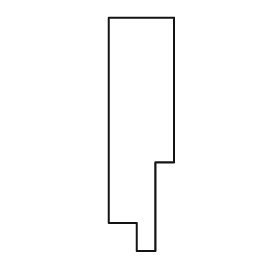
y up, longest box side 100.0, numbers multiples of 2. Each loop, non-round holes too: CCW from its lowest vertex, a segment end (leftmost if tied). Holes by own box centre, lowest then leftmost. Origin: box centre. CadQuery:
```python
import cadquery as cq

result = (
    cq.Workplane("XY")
    .moveTo(-2.0, -50.0)
    .lineTo(6.0, -50.0)
    .lineTo(6.0, -12.0)
    .lineTo(14.0, -12.0)
    .lineTo(14.0, 50.0)
    .lineTo(-14.0, 50.0)
    .lineTo(-14.0, -38.0)
    .lineTo(-2.0, -38.0)
    .close()
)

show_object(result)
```